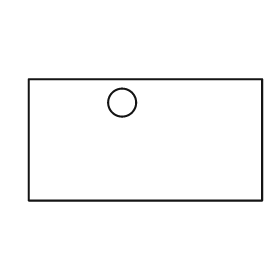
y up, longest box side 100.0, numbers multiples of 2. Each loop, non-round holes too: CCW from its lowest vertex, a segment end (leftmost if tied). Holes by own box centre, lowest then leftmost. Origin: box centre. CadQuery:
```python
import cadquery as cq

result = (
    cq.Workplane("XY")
    .moveTo(-50.0, -26.0)
    .lineTo(50.0, -26.0)
    .lineTo(50.0, 26.0)
    .lineTo(-50.0, 26.0)
    .close()
    .moveTo(-10.0, 16.0)
    .circle(6.0)
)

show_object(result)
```